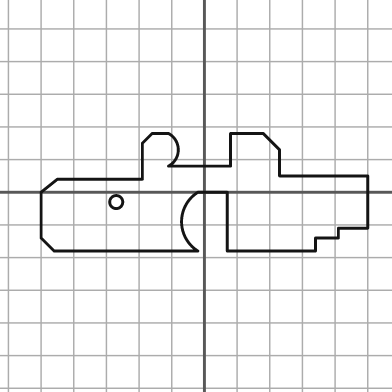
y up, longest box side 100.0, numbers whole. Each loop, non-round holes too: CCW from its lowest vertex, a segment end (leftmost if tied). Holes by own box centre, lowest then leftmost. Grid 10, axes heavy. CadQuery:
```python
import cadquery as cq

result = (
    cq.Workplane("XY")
    .moveTo(-46.0, -18.0)
    .lineTo(-2.0, -18.0)
    .threePointArc((-7.0, -9.0), (-2.0, 0.0))
    .lineTo(7.0, 0.0)
    .lineTo(7.0, -18.0)
    .lineTo(34.0, -18.0)
    .lineTo(34.0, -14.0)
    .lineTo(41.0, -14.0)
    .lineTo(41.0, -11.0)
    .lineTo(50.0, -11.0)
    .lineTo(50.0, 5.0)
    .lineTo(23.0, 5.0)
    .lineTo(23.0, 13.0)
    .lineTo(18.0, 18.0)
    .lineTo(8.0, 18.0)
    .lineTo(8.0, 8.0)
    .lineTo(-11.0, 8.0)
    .threePointArc((-8.0, 13.0), (-11.0, 18.0))
    .lineTo(-16.0, 18.0)
    .lineTo(-19.0, 15.0)
    .lineTo(-19.0, 4.0)
    .lineTo(-45.0, 4.0)
    .lineTo(-50.0, 0.0)
    .lineTo(-50.0, -14.0)
    .close()
    .moveTo(-27.0, -3.0)
    .circle(2.0)
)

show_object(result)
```